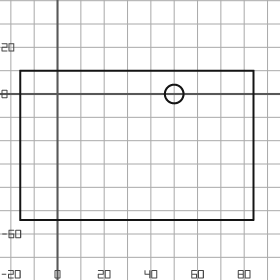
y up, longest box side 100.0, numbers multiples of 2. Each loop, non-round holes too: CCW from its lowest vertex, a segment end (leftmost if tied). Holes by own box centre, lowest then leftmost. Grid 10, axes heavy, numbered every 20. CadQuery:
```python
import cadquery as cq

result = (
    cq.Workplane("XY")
    .moveTo(-16.0, -54.0)
    .lineTo(84.0, -54.0)
    .lineTo(84.0, 10.0)
    .lineTo(-16.0, 10.0)
    .close()
    .moveTo(50.0, 0.0)
    .circle(4.0)
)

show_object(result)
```